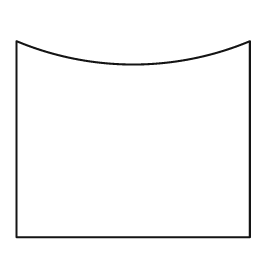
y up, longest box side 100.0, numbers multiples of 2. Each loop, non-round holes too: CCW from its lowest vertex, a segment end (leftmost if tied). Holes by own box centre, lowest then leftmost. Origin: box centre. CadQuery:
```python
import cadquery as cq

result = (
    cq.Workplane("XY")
    .moveTo(-50.0, -42.0)
    .lineTo(50.0, -42.0)
    .lineTo(50.0, 42.0)
    .threePointArc((0.0, 32.0), (-50.0, 42.0))
    .close()
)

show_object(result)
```